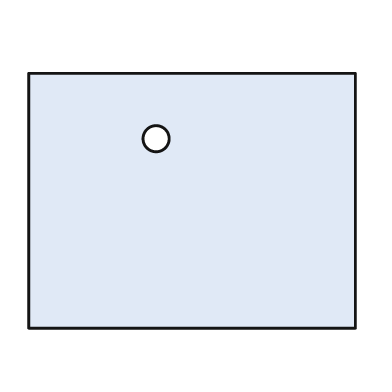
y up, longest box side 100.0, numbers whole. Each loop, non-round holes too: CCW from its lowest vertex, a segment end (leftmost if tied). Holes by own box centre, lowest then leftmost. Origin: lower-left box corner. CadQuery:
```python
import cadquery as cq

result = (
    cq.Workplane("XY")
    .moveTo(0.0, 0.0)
    .lineTo(100.0, 0.0)
    .lineTo(100.0, 78.0)
    .lineTo(0.0, 78.0)
    .close()
    .moveTo(39.0, 58.0)
    .circle(4.0)
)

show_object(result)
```